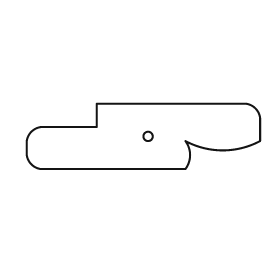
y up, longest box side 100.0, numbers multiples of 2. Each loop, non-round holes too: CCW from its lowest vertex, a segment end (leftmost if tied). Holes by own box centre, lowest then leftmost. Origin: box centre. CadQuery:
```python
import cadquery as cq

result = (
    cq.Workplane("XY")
    .moveTo(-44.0, -14.0)
    .lineTo(18.0, -14.0)
    .threePointArc((20.0, -8.0), (18.0, -2.0))
    .threePointArc((34.0, -6.0), (50.0, -2.0))
    .lineTo(50.0, 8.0)
    .threePointArc((48.0, 12.0), (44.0, 14.0))
    .lineTo(-20.0, 14.0)
    .lineTo(-20.0, 4.0)
    .lineTo(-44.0, 4.0)
    .threePointArc((-48.0, 2.0), (-50.0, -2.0))
    .lineTo(-50.0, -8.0)
    .threePointArc((-48.0, -12.0), (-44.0, -14.0))
    .close()
    .moveTo(2.0, 0.0)
    .circle(2.0)
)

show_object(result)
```